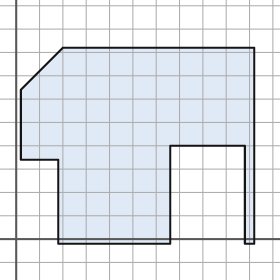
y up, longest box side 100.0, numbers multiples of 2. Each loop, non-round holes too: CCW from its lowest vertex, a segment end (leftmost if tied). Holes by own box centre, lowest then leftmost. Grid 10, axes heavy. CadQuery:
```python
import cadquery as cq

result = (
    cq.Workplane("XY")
    .moveTo(18.0, -2.0)
    .lineTo(66.0, -2.0)
    .lineTo(66.0, 40.0)
    .lineTo(98.0, 40.0)
    .lineTo(98.0, -2.0)
    .lineTo(102.0, -2.0)
    .lineTo(102.0, 82.0)
    .lineTo(20.0, 82.0)
    .lineTo(2.0, 64.0)
    .lineTo(2.0, 34.0)
    .lineTo(18.0, 34.0)
    .close()
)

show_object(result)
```